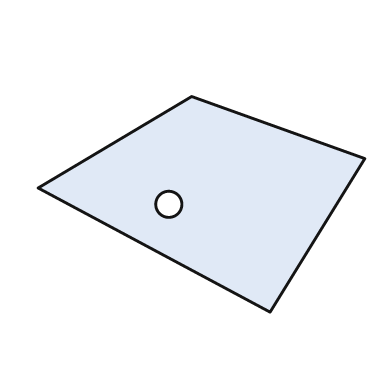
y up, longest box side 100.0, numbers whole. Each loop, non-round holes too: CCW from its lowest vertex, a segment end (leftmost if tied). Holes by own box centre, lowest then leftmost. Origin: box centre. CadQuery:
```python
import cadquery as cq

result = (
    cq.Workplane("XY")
    .moveTo(21.0, -33.0)
    .lineTo(50.0, 14.0)
    .lineTo(-3.0, 33.0)
    .lineTo(-50.0, 5.0)
    .close()
    .moveTo(-10.0, 0.0)
    .circle(4.0)
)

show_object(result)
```